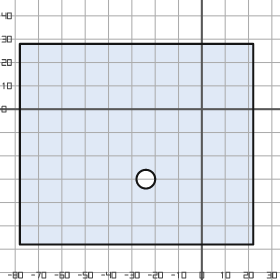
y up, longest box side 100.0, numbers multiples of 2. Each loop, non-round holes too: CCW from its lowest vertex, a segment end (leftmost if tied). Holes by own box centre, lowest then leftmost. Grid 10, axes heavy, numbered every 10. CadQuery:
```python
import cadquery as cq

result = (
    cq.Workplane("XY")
    .moveTo(-78.0, -58.0)
    .lineTo(22.0, -58.0)
    .lineTo(22.0, 28.0)
    .lineTo(-78.0, 28.0)
    .close()
    .moveTo(-24.0, -30.0)
    .circle(4.0)
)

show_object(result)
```